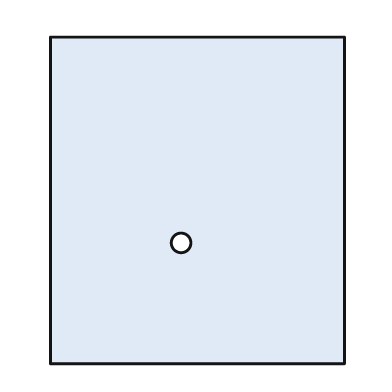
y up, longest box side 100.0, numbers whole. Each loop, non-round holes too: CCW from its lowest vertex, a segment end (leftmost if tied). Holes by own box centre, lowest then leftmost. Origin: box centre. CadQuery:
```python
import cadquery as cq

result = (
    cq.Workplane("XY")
    .moveTo(-45.0, -50.0)
    .lineTo(45.0, -50.0)
    .lineTo(45.0, 50.0)
    .lineTo(-45.0, 50.0)
    .close()
    .moveTo(-5.0, -13.0)
    .circle(3.0)
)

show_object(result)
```